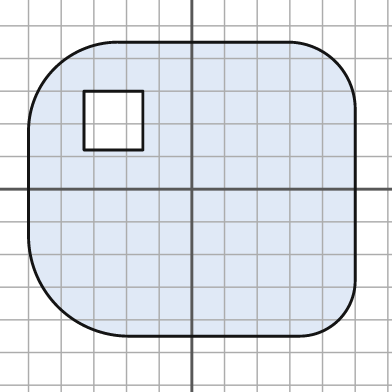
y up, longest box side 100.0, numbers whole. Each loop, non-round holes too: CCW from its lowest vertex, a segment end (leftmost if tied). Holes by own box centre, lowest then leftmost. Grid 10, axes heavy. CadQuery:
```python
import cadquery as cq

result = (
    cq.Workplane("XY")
    .moveTo(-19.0, -45.0)
    .lineTo(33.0, -45.0)
    .threePointArc((45.0, -40.0), (50.0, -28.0))
    .lineTo(50.0, 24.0)
    .threePointArc((44.0, 39.0), (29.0, 45.0))
    .lineTo(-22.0, 45.0)
    .threePointArc((-42.0, 37.0), (-50.0, 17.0))
    .lineTo(-50.0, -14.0)
    .threePointArc((-41.0, -36.0), (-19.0, -45.0))
    .close()
    .moveTo(-33.0, 12.0)
    .lineTo(-15.0, 12.0)
    .lineTo(-15.0, 30.0)
    .lineTo(-33.0, 30.0)
    .close()
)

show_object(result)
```